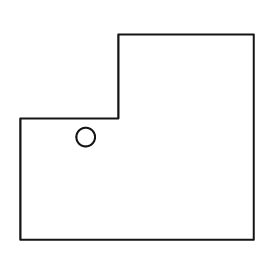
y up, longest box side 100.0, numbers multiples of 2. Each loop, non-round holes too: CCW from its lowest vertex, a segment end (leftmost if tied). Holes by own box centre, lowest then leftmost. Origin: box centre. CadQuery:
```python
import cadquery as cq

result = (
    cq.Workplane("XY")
    .moveTo(-50.0, -44.0)
    .lineTo(50.0, -44.0)
    .lineTo(50.0, 44.0)
    .lineTo(-8.0, 44.0)
    .lineTo(-8.0, 8.0)
    .lineTo(-50.0, 8.0)
    .close()
    .moveTo(-22.0, 0.0)
    .circle(4.0)
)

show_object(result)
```